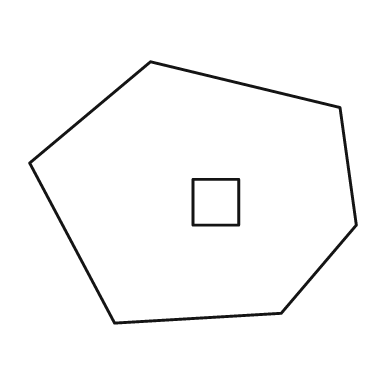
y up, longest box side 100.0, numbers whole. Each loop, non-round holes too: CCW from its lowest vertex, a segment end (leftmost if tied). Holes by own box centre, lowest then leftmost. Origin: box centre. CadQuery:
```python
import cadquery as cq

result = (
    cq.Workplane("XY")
    .moveTo(-24.0, -40.0)
    .lineTo(27.0, -37.0)
    .lineTo(50.0, -10.0)
    .lineTo(45.0, 26.0)
    .lineTo(-13.0, 40.0)
    .lineTo(-50.0, 9.0)
    .close()
    .moveTo(0.0, -10.0)
    .lineTo(14.0, -10.0)
    .lineTo(14.0, 4.0)
    .lineTo(0.0, 4.0)
    .close()
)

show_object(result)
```